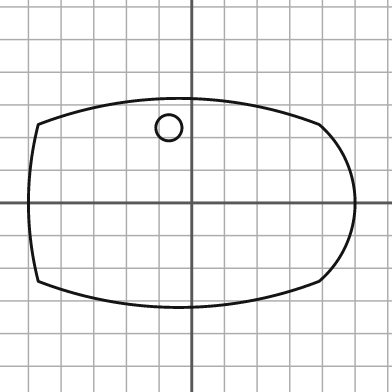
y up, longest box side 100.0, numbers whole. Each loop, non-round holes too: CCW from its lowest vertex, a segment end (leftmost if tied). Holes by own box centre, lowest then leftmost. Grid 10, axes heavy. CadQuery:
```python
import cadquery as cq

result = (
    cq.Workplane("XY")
    .moveTo(-47.0, -24.0)
    .threePointArc((-4.0, -32.0), (39.0, -24.0))
    .threePointArc((50.0, 0.0), (39.0, 24.0))
    .threePointArc((-4.0, 32.0), (-47.0, 24.0))
    .threePointArc((-50.0, 0.0), (-47.0, -24.0))
    .close()
    .moveTo(-7.0, 23.0)
    .circle(4.0)
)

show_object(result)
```